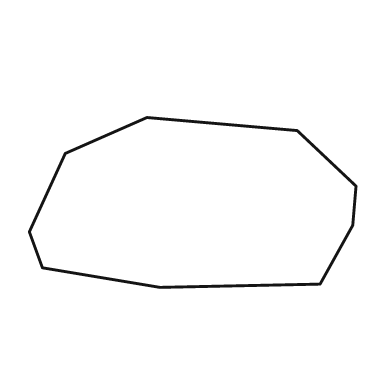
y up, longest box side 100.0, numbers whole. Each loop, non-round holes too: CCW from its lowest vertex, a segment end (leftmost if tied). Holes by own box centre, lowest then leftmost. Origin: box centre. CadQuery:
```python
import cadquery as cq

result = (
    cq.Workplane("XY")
    .moveTo(-10.0, -26.0)
    .lineTo(39.0, -25.0)
    .lineTo(49.0, -7.0)
    .lineTo(50.0, 5.0)
    .lineTo(32.0, 22.0)
    .lineTo(-14.0, 26.0)
    .lineTo(-39.0, 15.0)
    .lineTo(-50.0, -9.0)
    .lineTo(-46.0, -20.0)
    .close()
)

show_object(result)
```